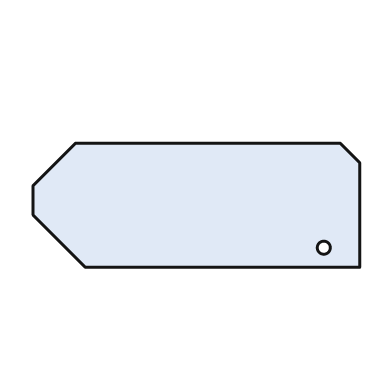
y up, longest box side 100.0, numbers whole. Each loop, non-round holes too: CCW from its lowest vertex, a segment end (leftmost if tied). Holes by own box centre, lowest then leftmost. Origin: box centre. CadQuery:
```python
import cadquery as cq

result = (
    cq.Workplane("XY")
    .moveTo(-34.0, -19.0)
    .lineTo(50.0, -19.0)
    .lineTo(50.0, 13.0)
    .lineTo(44.0, 19.0)
    .lineTo(-37.0, 19.0)
    .lineTo(-50.0, 6.0)
    .lineTo(-50.0, -3.0)
    .close()
    .moveTo(39.0, -13.0)
    .circle(2.0)
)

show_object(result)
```